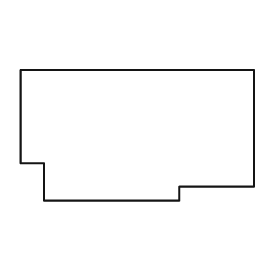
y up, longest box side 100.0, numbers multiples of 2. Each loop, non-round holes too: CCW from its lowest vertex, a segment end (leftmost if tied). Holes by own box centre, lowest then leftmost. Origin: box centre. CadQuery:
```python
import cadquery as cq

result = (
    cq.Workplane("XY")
    .moveTo(-40.0, -28.0)
    .lineTo(18.0, -28.0)
    .lineTo(18.0, -22.0)
    .lineTo(50.0, -22.0)
    .lineTo(50.0, 28.0)
    .lineTo(-50.0, 28.0)
    .lineTo(-50.0, -12.0)
    .lineTo(-40.0, -12.0)
    .close()
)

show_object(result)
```